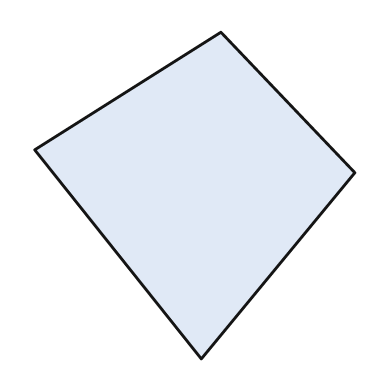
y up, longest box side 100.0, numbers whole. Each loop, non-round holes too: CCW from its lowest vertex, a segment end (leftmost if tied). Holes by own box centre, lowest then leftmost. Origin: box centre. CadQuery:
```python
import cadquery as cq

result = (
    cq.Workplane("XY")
    .moveTo(2.0, -50.0)
    .lineTo(49.0, 7.0)
    .lineTo(8.0, 50.0)
    .lineTo(-49.0, 14.0)
    .close()
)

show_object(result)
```